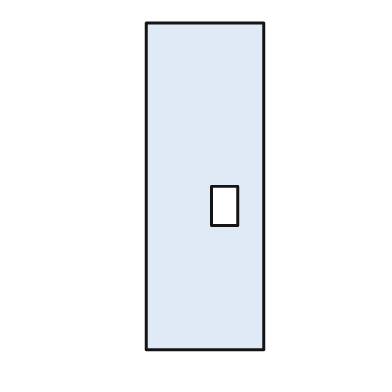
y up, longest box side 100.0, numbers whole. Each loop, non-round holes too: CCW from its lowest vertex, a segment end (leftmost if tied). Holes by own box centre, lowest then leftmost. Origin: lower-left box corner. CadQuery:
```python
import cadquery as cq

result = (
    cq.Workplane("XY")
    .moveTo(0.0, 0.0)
    .lineTo(36.0, 0.0)
    .lineTo(36.0, 100.0)
    .lineTo(0.0, 100.0)
    .close()
    .moveTo(20.0, 38.0)
    .lineTo(28.0, 38.0)
    .lineTo(28.0, 50.0)
    .lineTo(20.0, 50.0)
    .close()
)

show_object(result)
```